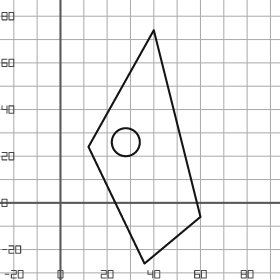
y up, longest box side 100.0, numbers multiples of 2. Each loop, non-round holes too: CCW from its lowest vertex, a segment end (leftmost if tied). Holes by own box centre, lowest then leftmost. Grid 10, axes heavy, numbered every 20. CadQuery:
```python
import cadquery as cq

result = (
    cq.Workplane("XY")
    .moveTo(36.0, -26.0)
    .lineTo(60.0, -6.0)
    .lineTo(40.0, 74.0)
    .lineTo(12.0, 24.0)
    .close()
    .moveTo(28.0, 26.0)
    .circle(6.0)
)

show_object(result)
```